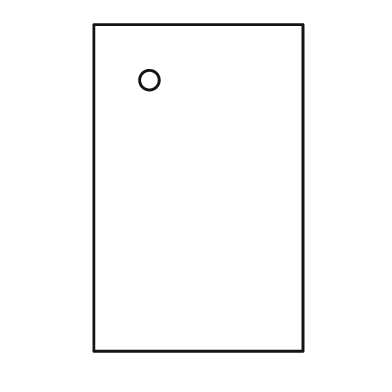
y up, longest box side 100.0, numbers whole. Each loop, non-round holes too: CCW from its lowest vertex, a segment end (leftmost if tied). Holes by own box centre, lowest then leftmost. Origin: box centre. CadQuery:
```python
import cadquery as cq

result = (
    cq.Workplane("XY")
    .moveTo(-32.0, -50.0)
    .lineTo(32.0, -50.0)
    .lineTo(32.0, 50.0)
    .lineTo(-32.0, 50.0)
    .close()
    .moveTo(-15.0, 33.0)
    .circle(3.0)
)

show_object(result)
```